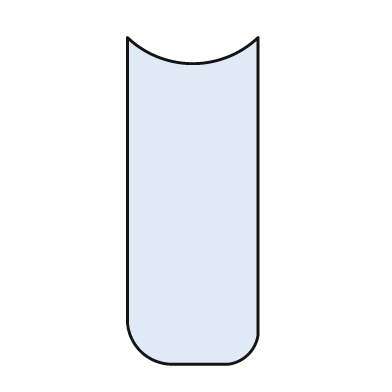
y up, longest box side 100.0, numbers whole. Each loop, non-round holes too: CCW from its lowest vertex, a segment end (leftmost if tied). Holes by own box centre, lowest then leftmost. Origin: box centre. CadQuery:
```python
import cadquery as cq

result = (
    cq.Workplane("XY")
    .moveTo(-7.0, -50.0)
    .lineTo(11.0, -50.0)
    .threePointArc((17.0, -47.0), (20.0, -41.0))
    .lineTo(20.0, 50.0)
    .threePointArc((0.0, 42.0), (-20.0, 50.0))
    .lineTo(-20.0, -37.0)
    .threePointArc((-16.0, -46.0), (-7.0, -50.0))
    .close()
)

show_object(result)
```